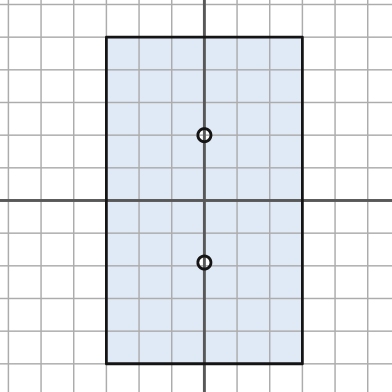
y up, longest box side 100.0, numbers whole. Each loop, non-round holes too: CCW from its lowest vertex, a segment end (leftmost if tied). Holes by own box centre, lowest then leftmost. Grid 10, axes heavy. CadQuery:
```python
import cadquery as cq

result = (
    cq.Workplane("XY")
    .moveTo(-30.0, -50.0)
    .lineTo(30.0, -50.0)
    .lineTo(30.0, 50.0)
    .lineTo(-30.0, 50.0)
    .close()
    .moveTo(0.0, -19.0)
    .circle(2.0)
    .moveTo(0.0, 20.0)
    .circle(2.0)
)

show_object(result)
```